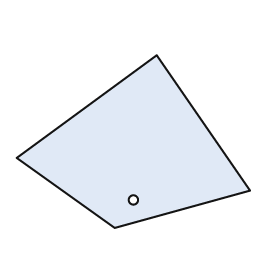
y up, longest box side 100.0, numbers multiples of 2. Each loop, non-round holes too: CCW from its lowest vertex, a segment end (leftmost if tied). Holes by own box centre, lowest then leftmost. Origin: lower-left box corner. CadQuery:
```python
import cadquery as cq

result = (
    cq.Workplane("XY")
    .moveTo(42.0, 0.0)
    .lineTo(100.0, 16.0)
    .lineTo(60.0, 74.0)
    .lineTo(0.0, 30.0)
    .close()
    .moveTo(50.0, 12.0)
    .circle(2.0)
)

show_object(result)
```